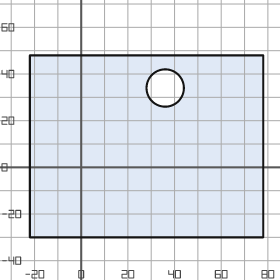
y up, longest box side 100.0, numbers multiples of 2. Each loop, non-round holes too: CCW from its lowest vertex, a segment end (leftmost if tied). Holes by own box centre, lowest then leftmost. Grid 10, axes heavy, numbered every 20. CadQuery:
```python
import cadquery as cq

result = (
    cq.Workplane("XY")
    .moveTo(-22.0, -30.0)
    .lineTo(78.0, -30.0)
    .lineTo(78.0, 48.0)
    .lineTo(-22.0, 48.0)
    .close()
    .moveTo(36.0, 34.0)
    .circle(8.0)
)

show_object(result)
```